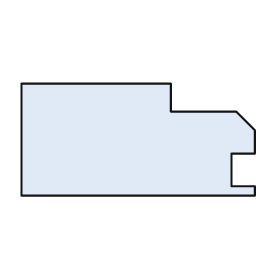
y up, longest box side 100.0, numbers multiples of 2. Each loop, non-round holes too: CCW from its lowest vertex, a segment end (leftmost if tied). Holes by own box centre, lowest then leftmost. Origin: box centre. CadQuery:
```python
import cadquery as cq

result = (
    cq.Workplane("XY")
    .moveTo(-50.0, -24.0)
    .lineTo(50.0, -24.0)
    .lineTo(50.0, -20.0)
    .lineTo(40.0, -20.0)
    .lineTo(40.0, -6.0)
    .lineTo(50.0, -6.0)
    .lineTo(50.0, 4.0)
    .lineTo(42.0, 12.0)
    .lineTo(14.0, 12.0)
    .lineTo(14.0, 24.0)
    .lineTo(-50.0, 24.0)
    .close()
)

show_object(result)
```